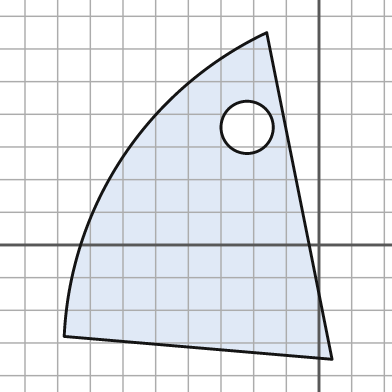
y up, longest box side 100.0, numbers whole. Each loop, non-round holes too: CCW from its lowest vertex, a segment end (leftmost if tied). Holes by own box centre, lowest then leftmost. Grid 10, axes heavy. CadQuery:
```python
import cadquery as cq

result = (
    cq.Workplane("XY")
    .moveTo(4.0, -35.0)
    .lineTo(-16.0, 65.0)
    .threePointArc((-60.0, 27.0), (-78.0, -28.0))
    .close()
    .moveTo(-22.0, 36.0)
    .circle(8.0)
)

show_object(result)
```